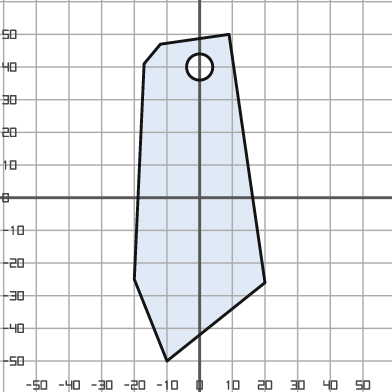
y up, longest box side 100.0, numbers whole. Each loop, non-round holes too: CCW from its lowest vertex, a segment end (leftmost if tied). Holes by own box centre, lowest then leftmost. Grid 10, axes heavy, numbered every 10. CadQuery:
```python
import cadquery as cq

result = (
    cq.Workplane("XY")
    .moveTo(-10.0, -50.0)
    .lineTo(20.0, -26.0)
    .lineTo(9.0, 50.0)
    .lineTo(-12.0, 47.0)
    .lineTo(-17.0, 41.0)
    .lineTo(-20.0, -25.0)
    .close()
    .moveTo(0.0, 40.0)
    .circle(4.0)
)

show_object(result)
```